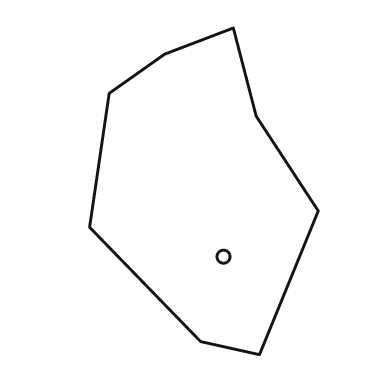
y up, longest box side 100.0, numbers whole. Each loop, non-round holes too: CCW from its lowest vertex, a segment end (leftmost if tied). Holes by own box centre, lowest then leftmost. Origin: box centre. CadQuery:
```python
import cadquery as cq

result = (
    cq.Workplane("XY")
    .moveTo(17.0, -50.0)
    .lineTo(35.0, -6.0)
    .lineTo(16.0, 23.0)
    .lineTo(9.0, 50.0)
    .lineTo(-12.0, 42.0)
    .lineTo(-29.0, 30.0)
    .lineTo(-35.0, -11.0)
    .lineTo(-1.0, -46.0)
    .close()
    .moveTo(6.0, -20.0)
    .circle(2.0)
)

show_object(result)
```